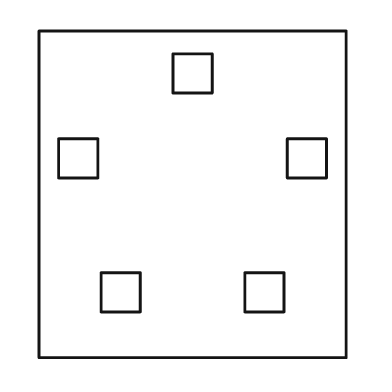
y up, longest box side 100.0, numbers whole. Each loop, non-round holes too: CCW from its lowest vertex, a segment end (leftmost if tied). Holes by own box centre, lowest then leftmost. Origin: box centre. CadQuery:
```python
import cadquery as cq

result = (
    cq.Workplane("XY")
    .moveTo(-47.0, -50.0)
    .lineTo(47.0, -50.0)
    .lineTo(47.0, 50.0)
    .lineTo(-47.0, 50.0)
    .close()
    .moveTo(-28.0, -36.0)
    .lineTo(-16.0, -36.0)
    .lineTo(-16.0, -24.0)
    .lineTo(-28.0, -24.0)
    .close()
    .moveTo(16.0, -36.0)
    .lineTo(28.0, -36.0)
    .lineTo(28.0, -24.0)
    .lineTo(16.0, -24.0)
    .close()
    .moveTo(-41.0, 5.0)
    .lineTo(-29.0, 5.0)
    .lineTo(-29.0, 17.0)
    .lineTo(-41.0, 17.0)
    .close()
    .moveTo(29.0, 5.0)
    .lineTo(41.0, 5.0)
    .lineTo(41.0, 17.0)
    .lineTo(29.0, 17.0)
    .close()
    .moveTo(-6.0, 31.0)
    .lineTo(6.0, 31.0)
    .lineTo(6.0, 43.0)
    .lineTo(-6.0, 43.0)
    .close()
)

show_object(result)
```